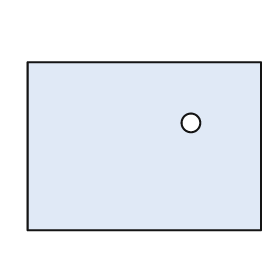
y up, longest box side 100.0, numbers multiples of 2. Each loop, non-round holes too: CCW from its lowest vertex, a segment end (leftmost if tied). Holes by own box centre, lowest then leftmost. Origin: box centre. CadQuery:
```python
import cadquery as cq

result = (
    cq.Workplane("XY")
    .moveTo(-50.0, -36.0)
    .lineTo(50.0, -36.0)
    .lineTo(50.0, 36.0)
    .lineTo(-50.0, 36.0)
    .close()
    .moveTo(20.0, 10.0)
    .circle(4.0)
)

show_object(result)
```